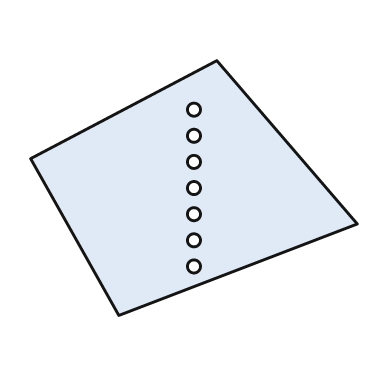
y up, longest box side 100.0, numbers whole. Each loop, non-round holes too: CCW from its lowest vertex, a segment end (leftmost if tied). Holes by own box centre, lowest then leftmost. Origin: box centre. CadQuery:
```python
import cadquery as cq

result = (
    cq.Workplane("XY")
    .moveTo(-23.0, -39.0)
    .lineTo(50.0, -11.0)
    .lineTo(7.0, 39.0)
    .lineTo(-50.0, 9.0)
    .close()
    .moveTo(0.0, -24.0)
    .circle(2.0)
    .moveTo(0.0, -16.0)
    .circle(2.0)
    .moveTo(0.0, -8.0)
    .circle(2.0)
    .moveTo(0.0, 0.0)
    .circle(2.0)
    .moveTo(0.0, 8.0)
    .circle(2.0)
    .moveTo(0.0, 16.0)
    .circle(2.0)
    .moveTo(0.0, 24.0)
    .circle(2.0)
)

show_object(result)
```